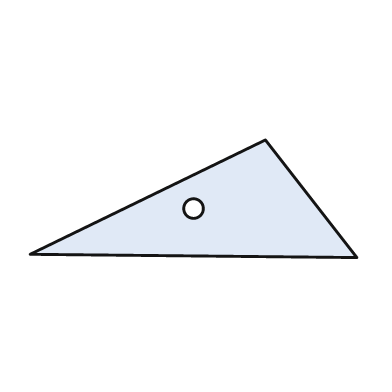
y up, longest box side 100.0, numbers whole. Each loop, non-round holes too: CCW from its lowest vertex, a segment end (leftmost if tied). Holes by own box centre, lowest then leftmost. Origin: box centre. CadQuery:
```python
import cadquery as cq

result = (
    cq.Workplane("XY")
    .moveTo(50.0, -18.0)
    .lineTo(22.0, 18.0)
    .lineTo(-50.0, -17.0)
    .close()
    .moveTo(0.0, -3.0)
    .circle(3.0)
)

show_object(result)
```